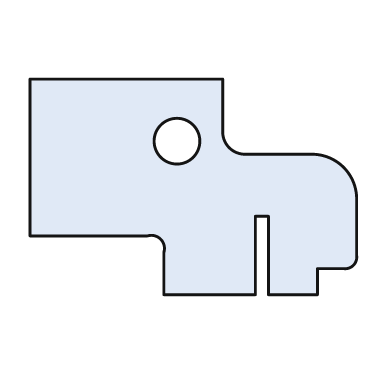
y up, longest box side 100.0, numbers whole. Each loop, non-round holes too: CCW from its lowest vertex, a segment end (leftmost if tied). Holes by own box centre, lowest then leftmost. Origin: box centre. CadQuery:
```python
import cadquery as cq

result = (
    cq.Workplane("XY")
    .moveTo(-9.0, -33.0)
    .lineTo(19.0, -33.0)
    .lineTo(19.0, -9.0)
    .lineTo(23.0, -9.0)
    .lineTo(23.0, -33.0)
    .lineTo(38.0, -33.0)
    .lineTo(38.0, -25.0)
    .lineTo(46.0, -25.0)
    .threePointArc((49.0, -24.0), (50.0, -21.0))
    .lineTo(50.0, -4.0)
    .threePointArc((46.0, 6.0), (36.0, 10.0))
    .lineTo(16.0, 10.0)
    .threePointArc((11.0, 12.0), (9.0, 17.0))
    .lineTo(9.0, 33.0)
    .lineTo(-50.0, 33.0)
    .lineTo(-50.0, -15.0)
    .lineTo(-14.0, -15.0)
    .threePointArc((-10.0, -16.0), (-9.0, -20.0))
    .close()
    .moveTo(-5.0, 14.0)
    .circle(7.0)
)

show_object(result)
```